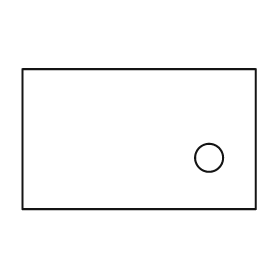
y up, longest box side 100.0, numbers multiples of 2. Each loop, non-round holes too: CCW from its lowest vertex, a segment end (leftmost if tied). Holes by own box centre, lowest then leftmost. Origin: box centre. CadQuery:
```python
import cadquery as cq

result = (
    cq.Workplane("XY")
    .moveTo(-50.0, -30.0)
    .lineTo(50.0, -30.0)
    .lineTo(50.0, 30.0)
    .lineTo(-50.0, 30.0)
    .close()
    .moveTo(30.0, -8.0)
    .circle(6.0)
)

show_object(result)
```